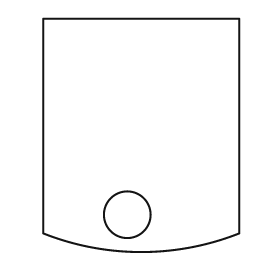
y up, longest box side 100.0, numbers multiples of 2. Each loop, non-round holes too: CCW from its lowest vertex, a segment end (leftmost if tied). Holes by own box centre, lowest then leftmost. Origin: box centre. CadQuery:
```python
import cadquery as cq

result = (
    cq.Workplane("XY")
    .moveTo(-42.0, -42.0)
    .threePointArc((0.0, -50.0), (42.0, -42.0))
    .lineTo(42.0, 50.0)
    .lineTo(-42.0, 50.0)
    .close()
    .moveTo(-6.0, -34.0)
    .circle(10.0)
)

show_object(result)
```